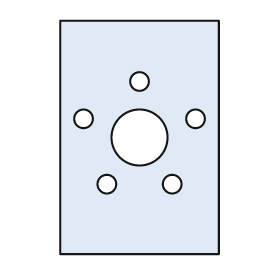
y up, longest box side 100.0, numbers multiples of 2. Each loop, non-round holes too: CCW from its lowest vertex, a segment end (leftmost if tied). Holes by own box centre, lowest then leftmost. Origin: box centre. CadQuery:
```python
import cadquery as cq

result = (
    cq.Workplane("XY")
    .moveTo(-34.0, -50.0)
    .lineTo(34.0, -50.0)
    .lineTo(34.0, 50.0)
    .lineTo(-34.0, 50.0)
    .close()
    .moveTo(-14.0, -20.0)
    .circle(4.0)
    .moveTo(14.0, -20.0)
    .circle(4.0)
    .moveTo(0.0, 0.0)
    .circle(12.0)
    .moveTo(-24.0, 8.0)
    .circle(4.0)
    .moveTo(24.0, 8.0)
    .circle(4.0)
    .moveTo(0.0, 24.0)
    .circle(4.0)
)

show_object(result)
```